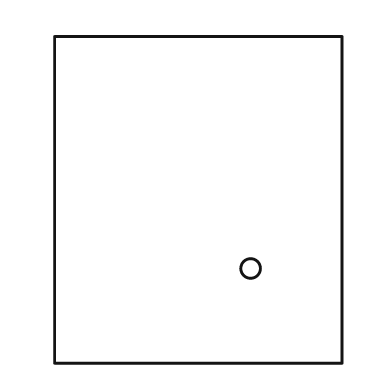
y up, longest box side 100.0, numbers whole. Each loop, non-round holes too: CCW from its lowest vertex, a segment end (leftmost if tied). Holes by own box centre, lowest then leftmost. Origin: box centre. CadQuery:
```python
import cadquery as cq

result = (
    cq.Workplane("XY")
    .moveTo(-44.0, -50.0)
    .lineTo(44.0, -50.0)
    .lineTo(44.0, 50.0)
    .lineTo(-44.0, 50.0)
    .close()
    .moveTo(16.0, -21.0)
    .circle(3.0)
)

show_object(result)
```